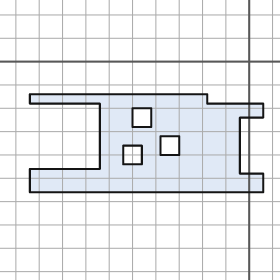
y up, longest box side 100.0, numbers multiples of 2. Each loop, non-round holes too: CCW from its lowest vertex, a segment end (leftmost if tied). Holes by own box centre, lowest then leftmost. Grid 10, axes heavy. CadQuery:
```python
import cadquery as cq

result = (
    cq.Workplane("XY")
    .moveTo(-94.0, -56.0)
    .lineTo(6.0, -56.0)
    .lineTo(6.0, -48.0)
    .lineTo(-4.0, -48.0)
    .lineTo(-4.0, -24.0)
    .lineTo(6.0, -24.0)
    .lineTo(6.0, -18.0)
    .lineTo(-18.0, -18.0)
    .lineTo(-18.0, -14.0)
    .lineTo(-94.0, -14.0)
    .lineTo(-94.0, -18.0)
    .lineTo(-64.0, -18.0)
    .lineTo(-64.0, -46.0)
    .lineTo(-94.0, -46.0)
    .close()
    .moveTo(-54.0, -44.0)
    .lineTo(-46.0, -44.0)
    .lineTo(-46.0, -36.0)
    .lineTo(-54.0, -36.0)
    .close()
    .moveTo(-38.0, -40.0)
    .lineTo(-30.0, -40.0)
    .lineTo(-30.0, -32.0)
    .lineTo(-38.0, -32.0)
    .close()
    .moveTo(-50.0, -28.0)
    .lineTo(-42.0, -28.0)
    .lineTo(-42.0, -20.0)
    .lineTo(-50.0, -20.0)
    .close()
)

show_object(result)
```